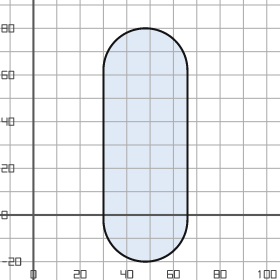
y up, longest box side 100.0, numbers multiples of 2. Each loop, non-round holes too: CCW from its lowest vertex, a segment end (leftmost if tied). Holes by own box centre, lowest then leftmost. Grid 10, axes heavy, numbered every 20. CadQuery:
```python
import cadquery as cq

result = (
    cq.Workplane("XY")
    .moveTo(30.0, -2.0)
    .threePointArc((48.0, -20.0), (66.0, -2.0))
    .lineTo(66.0, 62.0)
    .threePointArc((48.0, 80.0), (30.0, 62.0))
    .close()
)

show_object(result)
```